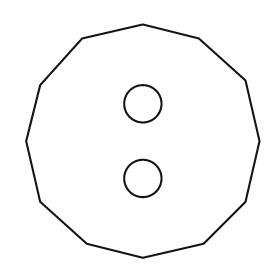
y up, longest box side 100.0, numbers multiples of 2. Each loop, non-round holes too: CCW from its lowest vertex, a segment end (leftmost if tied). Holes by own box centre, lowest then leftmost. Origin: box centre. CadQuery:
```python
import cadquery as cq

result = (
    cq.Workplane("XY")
    .moveTo(0.0, -50.0)
    .lineTo(26.0, -44.0)
    .lineTo(44.0, -26.0)
    .lineTo(50.0, 0.0)
    .lineTo(44.0, 26.0)
    .lineTo(24.0, 44.0)
    .lineTo(0.0, 50.0)
    .lineTo(-26.0, 44.0)
    .lineTo(-44.0, 24.0)
    .lineTo(-50.0, 0.0)
    .lineTo(-44.0, -26.0)
    .lineTo(-24.0, -44.0)
    .close()
    .moveTo(0.0, -16.0)
    .circle(8.0)
    .moveTo(0.0, 16.0)
    .circle(8.0)
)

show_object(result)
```